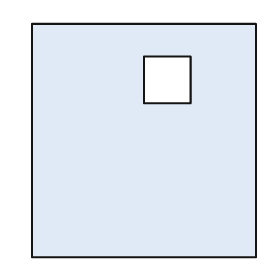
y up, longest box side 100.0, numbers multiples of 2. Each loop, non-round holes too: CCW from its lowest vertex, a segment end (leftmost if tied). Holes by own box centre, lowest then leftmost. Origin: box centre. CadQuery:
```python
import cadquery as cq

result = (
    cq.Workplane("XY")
    .moveTo(-48.0, -50.0)
    .lineTo(48.0, -50.0)
    .lineTo(48.0, 50.0)
    .lineTo(-48.0, 50.0)
    .close()
    .moveTo(0.0, 16.0)
    .lineTo(20.0, 16.0)
    .lineTo(20.0, 36.0)
    .lineTo(0.0, 36.0)
    .close()
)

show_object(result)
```